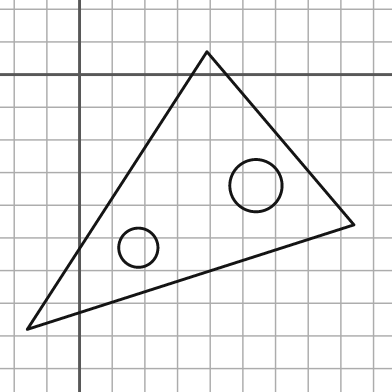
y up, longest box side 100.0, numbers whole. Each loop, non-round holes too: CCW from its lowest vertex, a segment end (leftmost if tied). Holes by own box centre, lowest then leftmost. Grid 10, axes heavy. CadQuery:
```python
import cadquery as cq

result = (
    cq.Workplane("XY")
    .moveTo(-16.0, -78.0)
    .lineTo(84.0, -46.0)
    .lineTo(39.0, 7.0)
    .close()
    .moveTo(18.0, -53.0)
    .circle(6.0)
    .moveTo(54.0, -34.0)
    .circle(8.0)
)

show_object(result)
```